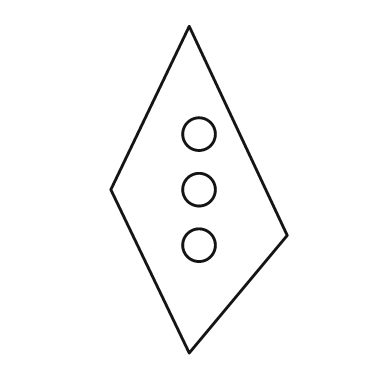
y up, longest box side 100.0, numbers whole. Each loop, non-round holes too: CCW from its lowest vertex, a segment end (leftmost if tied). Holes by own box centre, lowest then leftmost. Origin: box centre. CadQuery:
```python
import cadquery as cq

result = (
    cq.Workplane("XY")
    .moveTo(-3.0, -50.0)
    .lineTo(27.0, -14.0)
    .lineTo(-3.0, 50.0)
    .lineTo(-27.0, 0.0)
    .close()
    .moveTo(0.0, -17.0)
    .circle(5.0)
    .moveTo(0.0, 0.0)
    .circle(5.0)
    .moveTo(0.0, 17.0)
    .circle(5.0)
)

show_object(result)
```